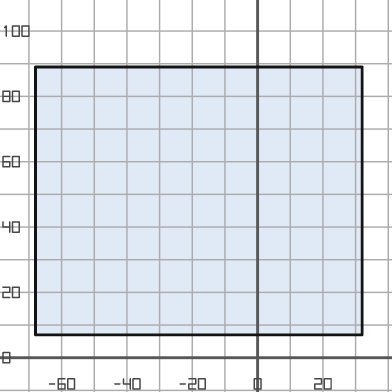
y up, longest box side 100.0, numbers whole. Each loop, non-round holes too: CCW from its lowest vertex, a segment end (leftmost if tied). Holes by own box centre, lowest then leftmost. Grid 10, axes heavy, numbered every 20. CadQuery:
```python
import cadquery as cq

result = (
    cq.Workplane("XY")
    .moveTo(-68.0, 7.0)
    .lineTo(32.0, 7.0)
    .lineTo(32.0, 89.0)
    .lineTo(-68.0, 89.0)
    .close()
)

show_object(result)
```